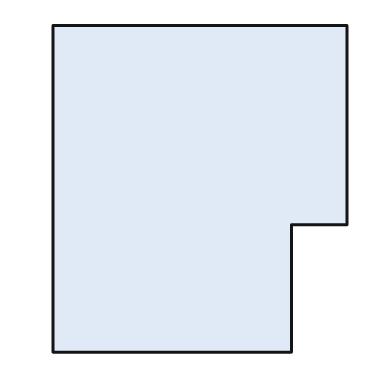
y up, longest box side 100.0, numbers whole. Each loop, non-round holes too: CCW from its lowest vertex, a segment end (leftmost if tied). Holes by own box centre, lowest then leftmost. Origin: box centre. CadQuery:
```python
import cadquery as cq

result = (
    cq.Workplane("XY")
    .moveTo(-45.0, -50.0)
    .lineTo(28.0, -50.0)
    .lineTo(28.0, -11.0)
    .lineTo(45.0, -11.0)
    .lineTo(45.0, 50.0)
    .lineTo(-45.0, 50.0)
    .close()
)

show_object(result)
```